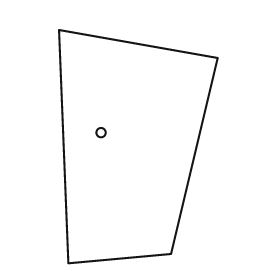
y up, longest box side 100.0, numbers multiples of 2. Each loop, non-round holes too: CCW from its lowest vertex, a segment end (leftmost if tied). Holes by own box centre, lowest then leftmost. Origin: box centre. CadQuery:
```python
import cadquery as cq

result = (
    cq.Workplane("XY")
    .moveTo(-30.0, -50.0)
    .lineTo(14.0, -46.0)
    .lineTo(34.0, 38.0)
    .lineTo(-34.0, 50.0)
    .close()
    .moveTo(-16.0, 6.0)
    .circle(2.0)
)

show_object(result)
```